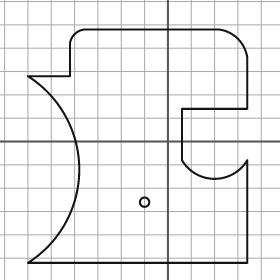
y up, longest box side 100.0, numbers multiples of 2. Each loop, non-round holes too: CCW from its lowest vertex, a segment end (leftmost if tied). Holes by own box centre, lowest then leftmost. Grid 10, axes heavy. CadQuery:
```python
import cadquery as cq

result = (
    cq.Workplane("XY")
    .moveTo(-60.0, -52.0)
    .lineTo(34.0, -52.0)
    .lineTo(34.0, -8.0)
    .threePointArc((20.0, -16.0), (6.0, -8.0))
    .lineTo(6.0, 14.0)
    .lineTo(34.0, 14.0)
    .lineTo(34.0, 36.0)
    .threePointArc((30.0, 44.0), (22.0, 48.0))
    .lineTo(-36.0, 48.0)
    .threePointArc((-40.0, 46.0), (-42.0, 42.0))
    .lineTo(-42.0, 28.0)
    .lineTo(-60.0, 28.0)
    .threePointArc((-38.0, -12.0), (-60.0, -52.0))
    .close()
    .moveTo(-10.0, -26.0)
    .circle(2.0)
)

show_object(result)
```